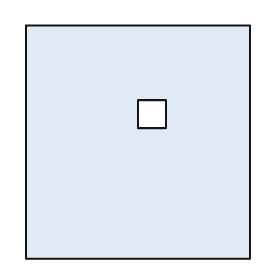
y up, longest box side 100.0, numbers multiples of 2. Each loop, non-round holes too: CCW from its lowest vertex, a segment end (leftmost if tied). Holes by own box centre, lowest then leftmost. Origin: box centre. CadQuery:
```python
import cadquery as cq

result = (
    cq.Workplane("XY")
    .moveTo(-48.0, -50.0)
    .lineTo(48.0, -50.0)
    .lineTo(48.0, 50.0)
    .lineTo(-48.0, 50.0)
    .close()
    .moveTo(0.0, 6.0)
    .lineTo(12.0, 6.0)
    .lineTo(12.0, 18.0)
    .lineTo(0.0, 18.0)
    .close()
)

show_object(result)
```